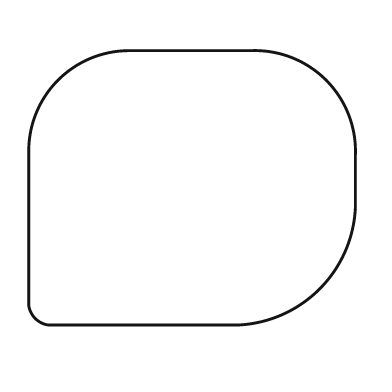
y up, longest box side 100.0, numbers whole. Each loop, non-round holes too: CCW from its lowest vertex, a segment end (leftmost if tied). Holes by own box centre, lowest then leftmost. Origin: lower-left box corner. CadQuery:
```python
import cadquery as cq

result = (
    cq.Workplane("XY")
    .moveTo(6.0, 0.0)
    .lineTo(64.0, 0.0)
    .threePointArc((89.0, 11.0), (100.0, 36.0))
    .lineTo(100.0, 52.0)
    .threePointArc((91.0, 75.0), (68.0, 84.0))
    .lineTo(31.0, 84.0)
    .threePointArc((9.0, 75.0), (0.0, 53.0))
    .lineTo(0.0, 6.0)
    .threePointArc((2.0, 2.0), (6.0, 0.0))
    .close()
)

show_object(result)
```